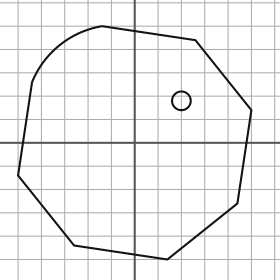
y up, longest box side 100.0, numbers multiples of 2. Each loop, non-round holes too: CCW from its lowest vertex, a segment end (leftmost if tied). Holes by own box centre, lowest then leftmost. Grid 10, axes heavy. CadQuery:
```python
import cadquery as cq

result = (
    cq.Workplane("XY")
    .moveTo(14.0, -50.0)
    .lineTo(44.0, -26.0)
    .lineTo(50.0, 14.0)
    .lineTo(26.0, 44.0)
    .lineTo(-14.0, 50.0)
    .threePointArc((-32.0, 42.0), (-44.0, 26.0))
    .lineTo(-50.0, -14.0)
    .lineTo(-26.0, -44.0)
    .close()
    .moveTo(20.0, 18.0)
    .circle(4.0)
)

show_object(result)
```